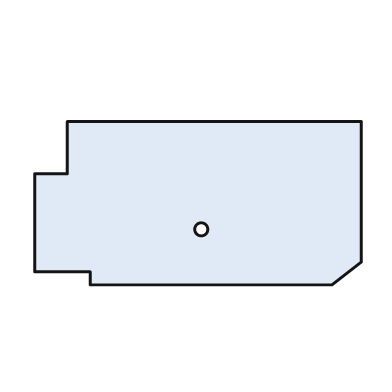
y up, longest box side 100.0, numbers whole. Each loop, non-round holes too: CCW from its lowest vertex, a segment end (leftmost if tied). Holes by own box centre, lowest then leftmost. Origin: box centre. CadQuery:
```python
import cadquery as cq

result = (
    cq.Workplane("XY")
    .moveTo(-33.0, -25.0)
    .lineTo(41.0, -25.0)
    .lineTo(50.0, -18.0)
    .lineTo(50.0, 25.0)
    .lineTo(-40.0, 25.0)
    .lineTo(-40.0, 9.0)
    .lineTo(-50.0, 9.0)
    .lineTo(-50.0, -21.0)
    .lineTo(-33.0, -21.0)
    .close()
    .moveTo(1.0, -8.0)
    .circle(2.0)
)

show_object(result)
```